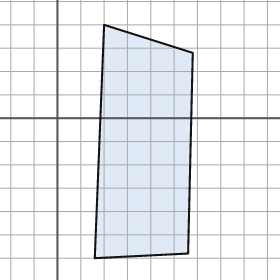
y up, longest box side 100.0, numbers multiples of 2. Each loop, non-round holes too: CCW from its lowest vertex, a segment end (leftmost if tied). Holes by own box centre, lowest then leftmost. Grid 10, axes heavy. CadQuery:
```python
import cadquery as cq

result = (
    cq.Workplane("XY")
    .moveTo(16.0, -60.0)
    .lineTo(56.0, -58.0)
    .lineTo(58.0, 28.0)
    .lineTo(20.0, 40.0)
    .close()
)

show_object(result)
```